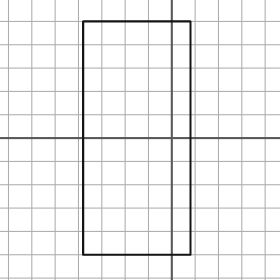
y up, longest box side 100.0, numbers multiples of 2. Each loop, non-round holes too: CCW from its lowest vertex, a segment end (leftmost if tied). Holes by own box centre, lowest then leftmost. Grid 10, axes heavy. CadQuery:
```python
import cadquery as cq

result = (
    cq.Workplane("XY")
    .moveTo(-38.0, -50.0)
    .lineTo(8.0, -50.0)
    .lineTo(8.0, 50.0)
    .lineTo(-38.0, 50.0)
    .close()
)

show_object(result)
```